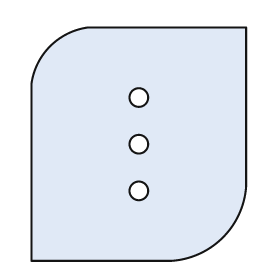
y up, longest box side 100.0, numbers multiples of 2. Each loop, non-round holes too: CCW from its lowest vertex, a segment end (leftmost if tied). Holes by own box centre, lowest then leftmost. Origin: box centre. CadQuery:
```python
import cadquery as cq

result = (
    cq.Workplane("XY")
    .moveTo(-46.0, -50.0)
    .lineTo(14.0, -50.0)
    .threePointArc((36.0, -40.0), (46.0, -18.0))
    .lineTo(46.0, 50.0)
    .lineTo(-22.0, 50.0)
    .threePointArc((-38.0, 42.0), (-46.0, 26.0))
    .close()
    .moveTo(0.0, -20.0)
    .circle(4.0)
    .moveTo(0.0, 0.0)
    .circle(4.0)
    .moveTo(0.0, 20.0)
    .circle(4.0)
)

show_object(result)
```